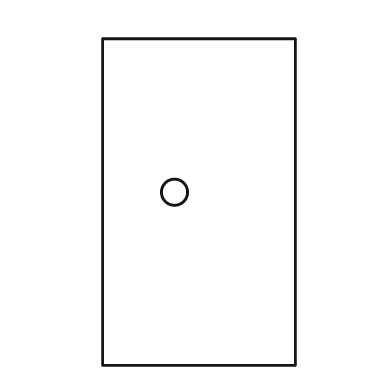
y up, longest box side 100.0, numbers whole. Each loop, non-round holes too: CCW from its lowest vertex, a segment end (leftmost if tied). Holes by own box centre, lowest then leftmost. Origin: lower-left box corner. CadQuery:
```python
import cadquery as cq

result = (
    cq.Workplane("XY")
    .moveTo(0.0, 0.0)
    .lineTo(59.0, 0.0)
    .lineTo(59.0, 100.0)
    .lineTo(0.0, 100.0)
    .close()
    .moveTo(22.0, 53.0)
    .circle(4.0)
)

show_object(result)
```